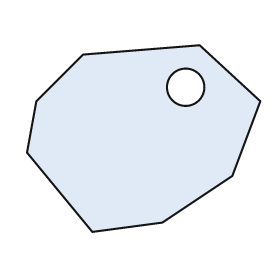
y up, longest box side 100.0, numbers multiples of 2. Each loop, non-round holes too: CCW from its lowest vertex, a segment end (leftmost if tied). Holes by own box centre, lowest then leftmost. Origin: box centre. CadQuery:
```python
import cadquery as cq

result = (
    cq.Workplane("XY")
    .moveTo(-22.0, -40.0)
    .lineTo(8.0, -36.0)
    .lineTo(38.0, -16.0)
    .lineTo(50.0, 16.0)
    .lineTo(24.0, 40.0)
    .lineTo(-26.0, 36.0)
    .lineTo(-46.0, 16.0)
    .lineTo(-50.0, -6.0)
    .close()
    .moveTo(18.0, 22.0)
    .circle(8.0)
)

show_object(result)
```